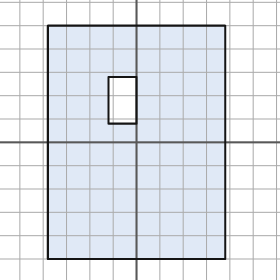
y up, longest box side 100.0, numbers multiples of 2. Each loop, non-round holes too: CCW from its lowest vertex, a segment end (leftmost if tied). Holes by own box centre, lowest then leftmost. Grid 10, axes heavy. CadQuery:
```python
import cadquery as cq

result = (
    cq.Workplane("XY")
    .moveTo(-38.0, -50.0)
    .lineTo(38.0, -50.0)
    .lineTo(38.0, 50.0)
    .lineTo(-38.0, 50.0)
    .close()
    .moveTo(-12.0, 8.0)
    .lineTo(0.0, 8.0)
    .lineTo(0.0, 28.0)
    .lineTo(-12.0, 28.0)
    .close()
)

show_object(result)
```